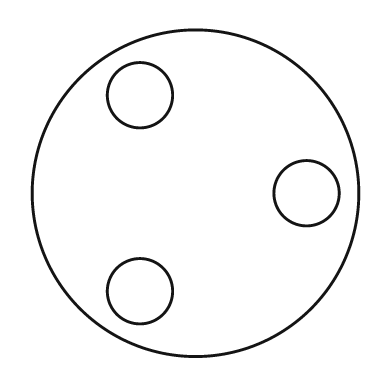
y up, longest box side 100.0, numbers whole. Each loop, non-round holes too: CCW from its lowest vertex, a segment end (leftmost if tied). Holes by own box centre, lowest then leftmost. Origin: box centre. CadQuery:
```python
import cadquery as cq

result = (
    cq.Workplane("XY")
    .moveTo(0.0, 0.0)
    .circle(50.0)
    .moveTo(-17.0, -30.0)
    .circle(10.0)
    .moveTo(34.0, 0.0)
    .circle(10.0)
    .moveTo(-17.0, 30.0)
    .circle(10.0)
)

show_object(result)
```